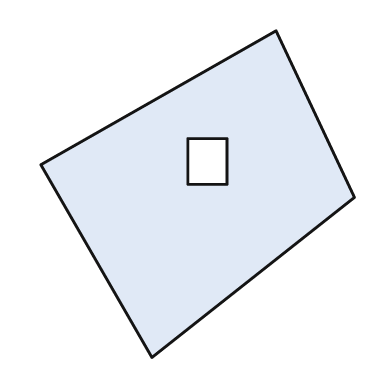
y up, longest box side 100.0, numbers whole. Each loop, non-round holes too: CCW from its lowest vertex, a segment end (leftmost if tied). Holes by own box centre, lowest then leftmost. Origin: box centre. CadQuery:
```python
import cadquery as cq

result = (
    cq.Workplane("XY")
    .moveTo(-14.0, -50.0)
    .lineTo(48.0, -1.0)
    .lineTo(24.0, 50.0)
    .lineTo(-48.0, 9.0)
    .close()
    .moveTo(-3.0, 3.0)
    .lineTo(9.0, 3.0)
    .lineTo(9.0, 17.0)
    .lineTo(-3.0, 17.0)
    .close()
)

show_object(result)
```